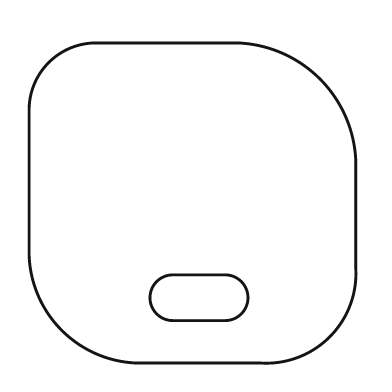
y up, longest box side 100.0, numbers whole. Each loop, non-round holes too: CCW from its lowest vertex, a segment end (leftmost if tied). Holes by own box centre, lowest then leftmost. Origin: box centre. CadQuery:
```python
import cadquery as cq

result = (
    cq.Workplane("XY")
    .moveTo(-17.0, -49.0)
    .lineTo(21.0, -49.0)
    .threePointArc((42.0, -41.0), (50.0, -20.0))
    .lineTo(50.0, 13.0)
    .threePointArc((39.0, 38.0), (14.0, 49.0))
    .lineTo(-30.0, 49.0)
    .threePointArc((-44.0, 43.0), (-50.0, 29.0))
    .lineTo(-50.0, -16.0)
    .threePointArc((-40.0, -39.0), (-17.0, -49.0))
    .close()
    .moveTo(-6.0, -36.0)
    .lineTo(10.0, -36.0)
    .threePointArc((17.0, -29.0), (10.0, -22.0))
    .lineTo(-6.0, -22.0)
    .threePointArc((-13.0, -29.0), (-6.0, -36.0))
    .close()
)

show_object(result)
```